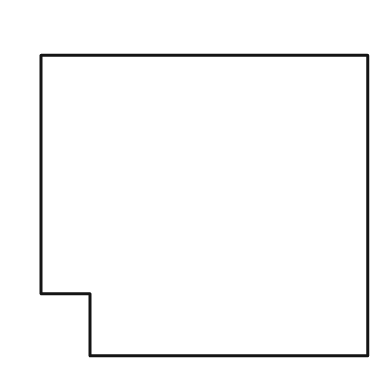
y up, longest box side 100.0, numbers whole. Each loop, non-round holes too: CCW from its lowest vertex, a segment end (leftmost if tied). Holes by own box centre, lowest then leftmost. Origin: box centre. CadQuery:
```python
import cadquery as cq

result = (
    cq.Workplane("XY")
    .moveTo(-35.0, -46.0)
    .lineTo(50.0, -46.0)
    .lineTo(50.0, 46.0)
    .lineTo(-50.0, 46.0)
    .lineTo(-50.0, -27.0)
    .lineTo(-35.0, -27.0)
    .close()
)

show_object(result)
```